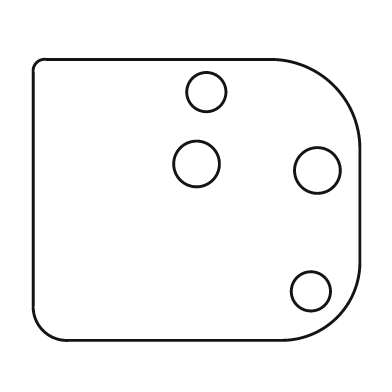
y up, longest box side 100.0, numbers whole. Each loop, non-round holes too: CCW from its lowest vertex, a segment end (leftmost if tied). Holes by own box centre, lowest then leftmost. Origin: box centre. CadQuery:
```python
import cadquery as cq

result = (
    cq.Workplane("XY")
    .moveTo(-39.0, -43.0)
    .lineTo(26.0, -43.0)
    .threePointArc((43.0, -36.0), (50.0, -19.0))
    .lineTo(50.0, 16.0)
    .threePointArc((42.0, 35.0), (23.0, 43.0))
    .lineTo(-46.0, 43.0)
    .threePointArc((-49.0, 42.0), (-50.0, 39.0))
    .lineTo(-50.0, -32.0)
    .threePointArc((-47.0, -40.0), (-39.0, -43.0))
    .close()
    .moveTo(35.0, -28.0)
    .circle(6.0)
    .moveTo(37.0, 9.0)
    .circle(7.0)
    .moveTo(0.0, 11.0)
    .circle(7.0)
    .moveTo(3.0, 33.0)
    .circle(6.0)
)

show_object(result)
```